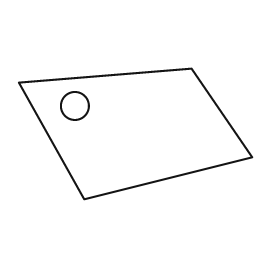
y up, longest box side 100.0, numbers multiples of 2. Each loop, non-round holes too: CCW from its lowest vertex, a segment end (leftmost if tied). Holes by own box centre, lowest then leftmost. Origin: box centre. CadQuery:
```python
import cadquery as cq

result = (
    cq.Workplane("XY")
    .moveTo(-22.0, -28.0)
    .lineTo(50.0, -10.0)
    .lineTo(24.0, 28.0)
    .lineTo(-50.0, 22.0)
    .close()
    .moveTo(-26.0, 12.0)
    .circle(6.0)
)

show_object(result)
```